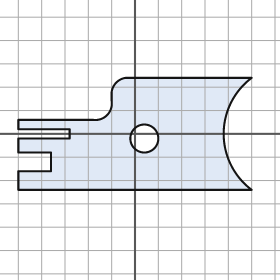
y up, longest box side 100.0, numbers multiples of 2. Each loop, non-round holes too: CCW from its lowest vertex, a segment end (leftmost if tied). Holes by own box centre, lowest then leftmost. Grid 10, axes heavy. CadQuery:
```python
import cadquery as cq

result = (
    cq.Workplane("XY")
    .moveTo(-50.0, -24.0)
    .lineTo(50.0, -24.0)
    .threePointArc((38.0, 0.0), (50.0, 24.0))
    .lineTo(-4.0, 24.0)
    .threePointArc((-8.0, 22.0), (-10.0, 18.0))
    .lineTo(-10.0, 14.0)
    .threePointArc((-12.0, 8.0), (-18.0, 6.0))
    .lineTo(-50.0, 6.0)
    .lineTo(-50.0, 2.0)
    .lineTo(-28.0, 2.0)
    .lineTo(-28.0, -2.0)
    .lineTo(-50.0, -2.0)
    .lineTo(-50.0, -8.0)
    .lineTo(-36.0, -8.0)
    .lineTo(-36.0, -16.0)
    .lineTo(-50.0, -16.0)
    .close()
    .moveTo(4.0, -2.0)
    .circle(6.0)
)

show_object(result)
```